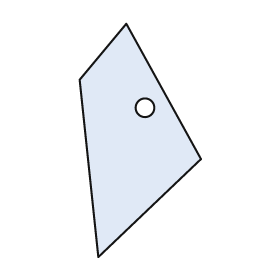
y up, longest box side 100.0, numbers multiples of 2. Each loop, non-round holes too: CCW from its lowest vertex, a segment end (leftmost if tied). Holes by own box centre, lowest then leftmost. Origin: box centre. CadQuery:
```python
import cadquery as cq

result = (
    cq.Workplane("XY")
    .moveTo(-18.0, -50.0)
    .lineTo(26.0, -8.0)
    .lineTo(-6.0, 50.0)
    .lineTo(-26.0, 26.0)
    .close()
    .moveTo(2.0, 14.0)
    .circle(4.0)
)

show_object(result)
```